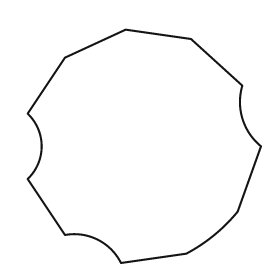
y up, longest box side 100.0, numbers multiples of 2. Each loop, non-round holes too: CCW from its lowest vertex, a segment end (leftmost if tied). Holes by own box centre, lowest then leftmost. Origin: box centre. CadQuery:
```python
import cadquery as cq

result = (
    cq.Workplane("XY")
    .moveTo(-10.0, -50.0)
    .lineTo(18.0, -46.0)
    .threePointArc((30.0, -38.0), (40.0, -28.0))
    .lineTo(50.0, 0.0)
    .threePointArc((42.0, 12.0), (42.0, 26.0))
    .lineTo(20.0, 46.0)
    .lineTo(-8.0, 50.0)
    .lineTo(-34.0, 38.0)
    .lineTo(-50.0, 14.0)
    .threePointArc((-44.0, 0.0), (-50.0, -14.0))
    .lineTo(-34.0, -38.0)
    .threePointArc((-20.0, -40.0), (-10.0, -50.0))
    .close()
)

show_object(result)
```